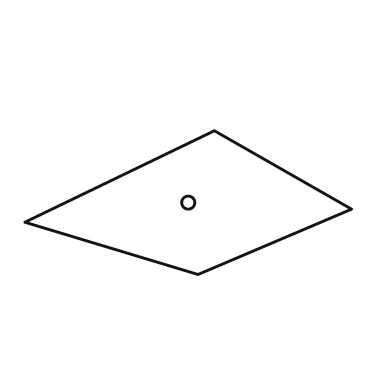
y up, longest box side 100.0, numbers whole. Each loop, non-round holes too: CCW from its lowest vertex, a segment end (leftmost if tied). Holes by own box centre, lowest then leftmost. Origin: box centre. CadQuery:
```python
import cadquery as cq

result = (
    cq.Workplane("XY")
    .moveTo(3.0, -22.0)
    .lineTo(50.0, -2.0)
    .lineTo(8.0, 22.0)
    .lineTo(-50.0, -6.0)
    .close()
    .moveTo(0.0, 0.0)
    .circle(2.0)
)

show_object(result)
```